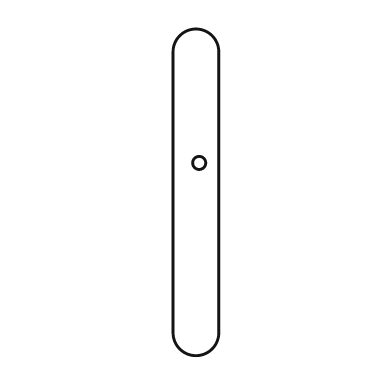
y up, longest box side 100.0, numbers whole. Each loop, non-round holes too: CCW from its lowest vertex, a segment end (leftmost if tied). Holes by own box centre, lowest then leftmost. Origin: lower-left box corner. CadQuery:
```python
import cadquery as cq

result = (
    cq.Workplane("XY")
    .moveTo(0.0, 7.0)
    .threePointArc((7.0, 0.0), (14.0, 7.0))
    .lineTo(14.0, 93.0)
    .threePointArc((7.0, 100.0), (0.0, 93.0))
    .close()
    .moveTo(8.0, 59.0)
    .circle(2.0)
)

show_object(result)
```